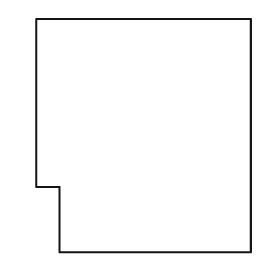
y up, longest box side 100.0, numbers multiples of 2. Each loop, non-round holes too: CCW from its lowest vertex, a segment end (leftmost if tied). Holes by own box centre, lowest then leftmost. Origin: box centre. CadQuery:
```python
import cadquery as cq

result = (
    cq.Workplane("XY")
    .moveTo(-36.0, -50.0)
    .lineTo(46.0, -50.0)
    .lineTo(46.0, 50.0)
    .lineTo(-46.0, 50.0)
    .lineTo(-46.0, -22.0)
    .lineTo(-36.0, -22.0)
    .close()
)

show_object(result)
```